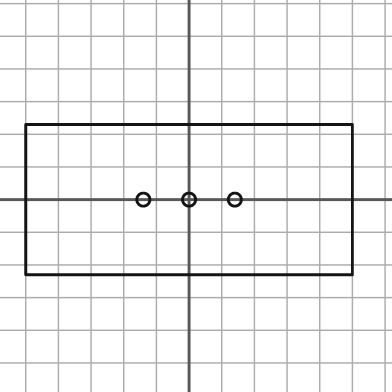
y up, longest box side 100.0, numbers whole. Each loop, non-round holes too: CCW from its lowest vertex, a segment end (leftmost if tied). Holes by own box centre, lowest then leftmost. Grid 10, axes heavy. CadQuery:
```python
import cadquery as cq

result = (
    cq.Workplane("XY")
    .moveTo(-50.0, -23.0)
    .lineTo(50.0, -23.0)
    .lineTo(50.0, 23.0)
    .lineTo(-50.0, 23.0)
    .close()
    .moveTo(-14.0, 0.0)
    .circle(2.0)
    .moveTo(0.0, 0.0)
    .circle(2.0)
    .moveTo(14.0, 0.0)
    .circle(2.0)
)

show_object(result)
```